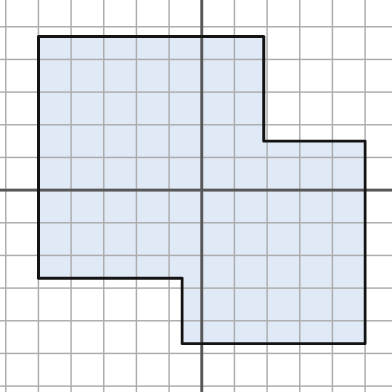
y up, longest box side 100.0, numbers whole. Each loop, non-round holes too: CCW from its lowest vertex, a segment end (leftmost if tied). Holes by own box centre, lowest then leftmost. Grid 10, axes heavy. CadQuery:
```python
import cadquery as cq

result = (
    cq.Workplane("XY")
    .moveTo(-6.0, -47.0)
    .lineTo(50.0, -47.0)
    .lineTo(50.0, 15.0)
    .lineTo(19.0, 15.0)
    .lineTo(19.0, 47.0)
    .lineTo(-50.0, 47.0)
    .lineTo(-50.0, -27.0)
    .lineTo(-6.0, -27.0)
    .close()
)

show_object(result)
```